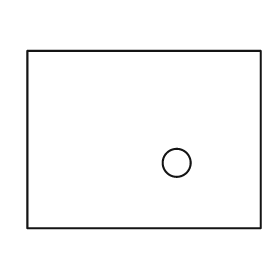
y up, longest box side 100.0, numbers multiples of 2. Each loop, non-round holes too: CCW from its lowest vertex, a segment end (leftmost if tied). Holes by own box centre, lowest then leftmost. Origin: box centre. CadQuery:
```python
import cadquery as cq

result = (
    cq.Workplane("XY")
    .moveTo(-50.0, -38.0)
    .lineTo(50.0, -38.0)
    .lineTo(50.0, 38.0)
    .lineTo(-50.0, 38.0)
    .close()
    .moveTo(14.0, -10.0)
    .circle(6.0)
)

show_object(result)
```